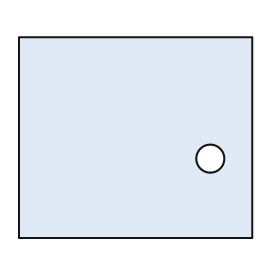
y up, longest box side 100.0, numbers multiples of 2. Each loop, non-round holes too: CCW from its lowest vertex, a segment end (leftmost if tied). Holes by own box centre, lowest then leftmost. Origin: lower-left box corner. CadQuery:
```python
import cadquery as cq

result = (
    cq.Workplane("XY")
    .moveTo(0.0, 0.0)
    .lineTo(100.0, 0.0)
    .lineTo(100.0, 86.0)
    .lineTo(0.0, 86.0)
    .close()
    .moveTo(82.0, 34.0)
    .circle(6.0)
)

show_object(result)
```